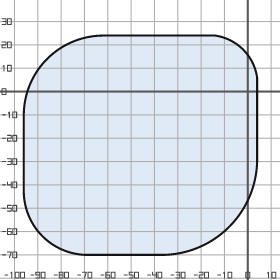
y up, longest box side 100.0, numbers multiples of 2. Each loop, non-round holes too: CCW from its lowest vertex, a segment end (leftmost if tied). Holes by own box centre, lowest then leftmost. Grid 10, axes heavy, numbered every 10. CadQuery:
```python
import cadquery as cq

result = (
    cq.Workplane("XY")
    .moveTo(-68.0, -70.0)
    .lineTo(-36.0, -70.0)
    .threePointArc((-8.0, -58.0), (4.0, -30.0))
    .lineTo(4.0, 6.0)
    .threePointArc((-2.0, 18.0), (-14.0, 24.0))
    .lineTo(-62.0, 24.0)
    .threePointArc((-86.0, 14.0), (-96.0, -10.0))
    .lineTo(-96.0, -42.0)
    .threePointArc((-88.0, -62.0), (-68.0, -70.0))
    .close()
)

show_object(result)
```